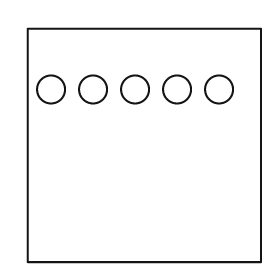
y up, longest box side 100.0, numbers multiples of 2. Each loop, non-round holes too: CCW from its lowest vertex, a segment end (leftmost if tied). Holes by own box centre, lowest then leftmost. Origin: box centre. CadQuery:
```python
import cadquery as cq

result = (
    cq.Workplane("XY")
    .moveTo(-50.0, -50.0)
    .lineTo(50.0, -50.0)
    .lineTo(50.0, 50.0)
    .lineTo(-50.0, 50.0)
    .close()
    .moveTo(-40.0, 24.0)
    .circle(6.0)
    .moveTo(-22.0, 24.0)
    .circle(6.0)
    .moveTo(-4.0, 24.0)
    .circle(6.0)
    .moveTo(14.0, 24.0)
    .circle(6.0)
    .moveTo(32.0, 24.0)
    .circle(6.0)
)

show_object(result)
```